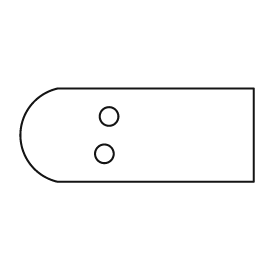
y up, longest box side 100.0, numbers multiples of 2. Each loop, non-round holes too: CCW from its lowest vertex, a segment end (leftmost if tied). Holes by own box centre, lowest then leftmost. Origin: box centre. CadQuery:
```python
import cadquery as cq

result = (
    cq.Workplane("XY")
    .moveTo(-34.0, -20.0)
    .lineTo(50.0, -20.0)
    .lineTo(50.0, 20.0)
    .lineTo(-34.0, 20.0)
    .threePointArc((-50.0, 0.0), (-34.0, -20.0))
    .close()
    .moveTo(-14.0, -8.0)
    .circle(4.0)
    .moveTo(-12.0, 8.0)
    .circle(4.0)
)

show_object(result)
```